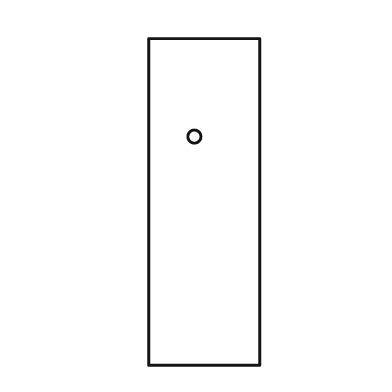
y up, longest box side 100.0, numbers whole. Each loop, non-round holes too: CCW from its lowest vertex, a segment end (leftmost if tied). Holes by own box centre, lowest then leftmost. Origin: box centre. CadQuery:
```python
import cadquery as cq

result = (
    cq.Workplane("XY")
    .moveTo(-17.0, -50.0)
    .lineTo(17.0, -50.0)
    .lineTo(17.0, 50.0)
    .lineTo(-17.0, 50.0)
    .close()
    .moveTo(-3.0, 20.0)
    .circle(2.0)
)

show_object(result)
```